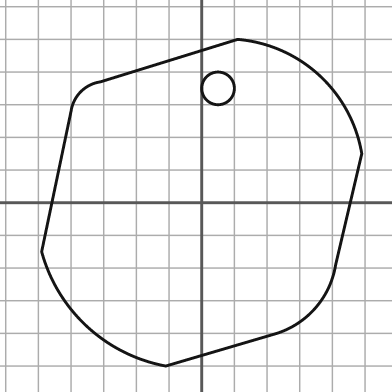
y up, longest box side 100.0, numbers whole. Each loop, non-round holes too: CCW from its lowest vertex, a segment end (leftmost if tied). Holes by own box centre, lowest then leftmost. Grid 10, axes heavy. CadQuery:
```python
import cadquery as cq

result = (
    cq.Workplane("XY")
    .moveTo(-11.0, -50.0)
    .lineTo(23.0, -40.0)
    .threePointArc((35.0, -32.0), (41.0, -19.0))
    .lineTo(49.0, 15.0)
    .threePointArc((36.0, 39.0), (11.0, 50.0))
    .lineTo(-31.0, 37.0)
    .threePointArc((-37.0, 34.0), (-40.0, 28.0))
    .lineTo(-49.0, -15.0)
    .threePointArc((-35.0, -38.0), (-11.0, -50.0))
    .close()
    .moveTo(5.0, 35.0)
    .circle(5.0)
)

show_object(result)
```